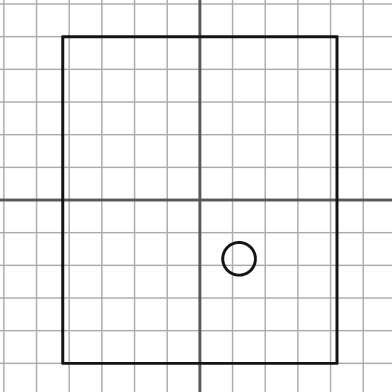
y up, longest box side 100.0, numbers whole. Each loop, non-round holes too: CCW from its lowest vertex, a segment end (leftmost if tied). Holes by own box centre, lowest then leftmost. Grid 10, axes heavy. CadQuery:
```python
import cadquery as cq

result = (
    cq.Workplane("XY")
    .moveTo(-42.0, -50.0)
    .lineTo(42.0, -50.0)
    .lineTo(42.0, 50.0)
    .lineTo(-42.0, 50.0)
    .close()
    .moveTo(12.0, -18.0)
    .circle(5.0)
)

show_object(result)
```